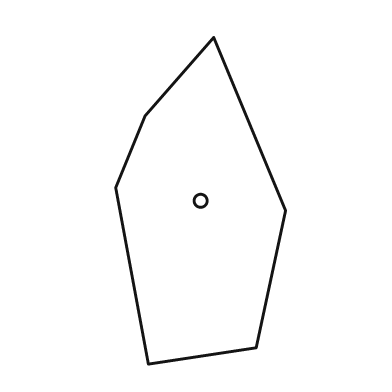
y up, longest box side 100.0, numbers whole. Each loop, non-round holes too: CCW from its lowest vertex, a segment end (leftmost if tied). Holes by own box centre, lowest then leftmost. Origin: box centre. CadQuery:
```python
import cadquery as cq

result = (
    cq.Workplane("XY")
    .moveTo(-16.0, -50.0)
    .lineTo(17.0, -45.0)
    .lineTo(26.0, -3.0)
    .lineTo(4.0, 50.0)
    .lineTo(-17.0, 26.0)
    .lineTo(-26.0, 4.0)
    .close()
    .moveTo(0.0, 0.0)
    .circle(2.0)
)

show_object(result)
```